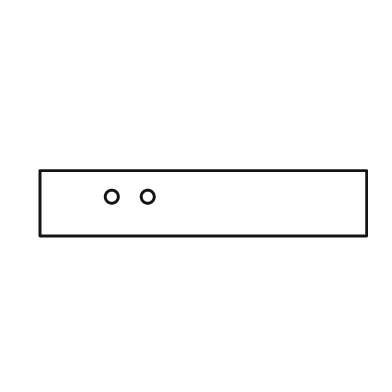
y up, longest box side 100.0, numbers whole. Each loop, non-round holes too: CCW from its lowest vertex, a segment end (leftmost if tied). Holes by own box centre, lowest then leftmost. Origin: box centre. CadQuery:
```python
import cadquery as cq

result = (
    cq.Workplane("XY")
    .moveTo(-50.0, -10.0)
    .lineTo(50.0, -10.0)
    .lineTo(50.0, 10.0)
    .lineTo(-50.0, 10.0)
    .close()
    .moveTo(-28.0, 2.0)
    .circle(2.0)
    .moveTo(-17.0, 2.0)
    .circle(2.0)
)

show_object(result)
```